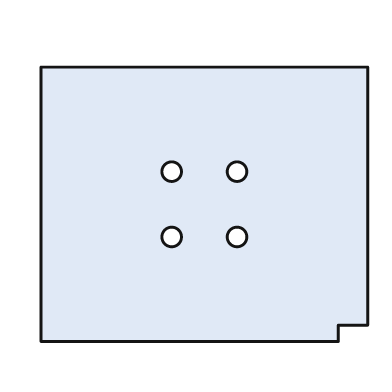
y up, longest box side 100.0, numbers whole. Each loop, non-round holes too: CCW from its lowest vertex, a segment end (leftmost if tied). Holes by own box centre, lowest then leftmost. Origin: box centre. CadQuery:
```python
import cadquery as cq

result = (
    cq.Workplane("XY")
    .moveTo(-50.0, -42.0)
    .lineTo(41.0, -42.0)
    .lineTo(41.0, -37.0)
    .lineTo(50.0, -37.0)
    .lineTo(50.0, 42.0)
    .lineTo(-50.0, 42.0)
    .close()
    .moveTo(-10.0, -10.0)
    .circle(3.0)
    .moveTo(10.0, -10.0)
    .circle(3.0)
    .moveTo(-10.0, 10.0)
    .circle(3.0)
    .moveTo(10.0, 10.0)
    .circle(3.0)
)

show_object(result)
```